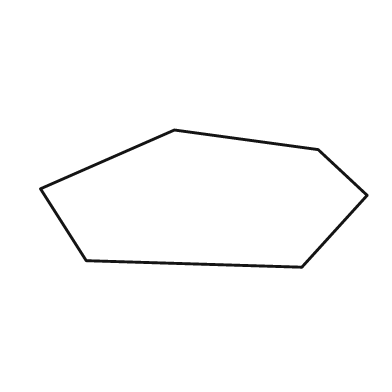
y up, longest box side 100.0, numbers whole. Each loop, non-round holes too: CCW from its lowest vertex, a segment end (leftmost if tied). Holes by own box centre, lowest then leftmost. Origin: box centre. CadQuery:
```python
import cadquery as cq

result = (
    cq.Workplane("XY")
    .moveTo(30.0, -21.0)
    .lineTo(50.0, 1.0)
    .lineTo(35.0, 15.0)
    .lineTo(-9.0, 21.0)
    .lineTo(-50.0, 3.0)
    .lineTo(-36.0, -19.0)
    .close()
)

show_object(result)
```